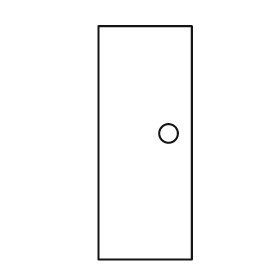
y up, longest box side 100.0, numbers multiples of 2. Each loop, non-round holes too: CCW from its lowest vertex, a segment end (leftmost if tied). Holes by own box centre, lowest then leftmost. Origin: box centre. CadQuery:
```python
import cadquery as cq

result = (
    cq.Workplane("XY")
    .moveTo(-20.0, -50.0)
    .lineTo(20.0, -50.0)
    .lineTo(20.0, 50.0)
    .lineTo(-20.0, 50.0)
    .close()
    .moveTo(10.0, 4.0)
    .circle(4.0)
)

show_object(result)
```